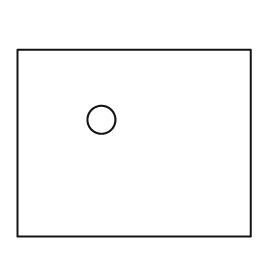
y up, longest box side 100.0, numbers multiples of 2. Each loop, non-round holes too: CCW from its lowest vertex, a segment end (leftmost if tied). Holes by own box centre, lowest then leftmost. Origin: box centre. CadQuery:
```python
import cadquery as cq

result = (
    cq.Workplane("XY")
    .moveTo(-50.0, -40.0)
    .lineTo(50.0, -40.0)
    .lineTo(50.0, 40.0)
    .lineTo(-50.0, 40.0)
    .close()
    .moveTo(-14.0, 10.0)
    .circle(6.0)
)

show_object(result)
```